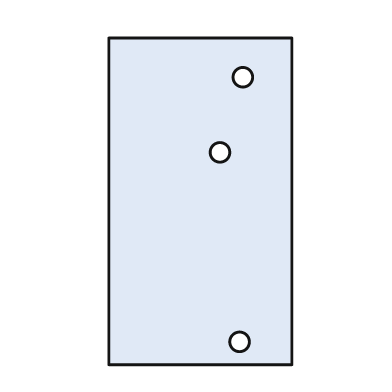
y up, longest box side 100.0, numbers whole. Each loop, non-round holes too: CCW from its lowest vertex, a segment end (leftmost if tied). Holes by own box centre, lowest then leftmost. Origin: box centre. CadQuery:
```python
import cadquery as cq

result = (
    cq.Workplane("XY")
    .moveTo(-28.0, -50.0)
    .lineTo(28.0, -50.0)
    .lineTo(28.0, 50.0)
    .lineTo(-28.0, 50.0)
    .close()
    .moveTo(12.0, -43.0)
    .circle(3.0)
    .moveTo(6.0, 15.0)
    .circle(3.0)
    .moveTo(13.0, 38.0)
    .circle(3.0)
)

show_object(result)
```